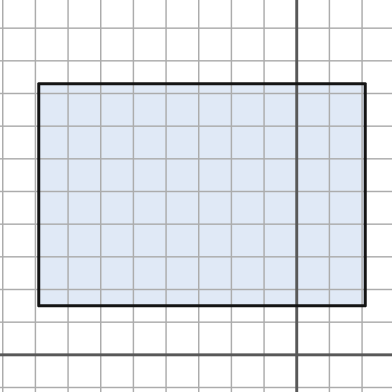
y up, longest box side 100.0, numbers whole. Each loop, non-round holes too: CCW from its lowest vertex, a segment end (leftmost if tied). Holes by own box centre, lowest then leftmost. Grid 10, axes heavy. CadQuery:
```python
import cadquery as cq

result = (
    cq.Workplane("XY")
    .moveTo(-79.0, 15.0)
    .lineTo(21.0, 15.0)
    .lineTo(21.0, 83.0)
    .lineTo(-79.0, 83.0)
    .close()
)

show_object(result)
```